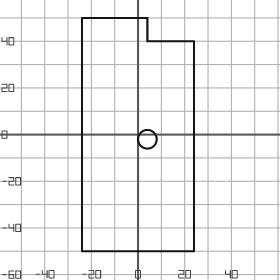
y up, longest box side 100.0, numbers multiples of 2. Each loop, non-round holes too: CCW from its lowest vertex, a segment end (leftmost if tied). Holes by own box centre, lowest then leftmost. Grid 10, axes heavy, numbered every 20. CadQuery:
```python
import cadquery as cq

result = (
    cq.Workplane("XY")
    .moveTo(-24.0, -50.0)
    .lineTo(24.0, -50.0)
    .lineTo(24.0, 40.0)
    .lineTo(4.0, 40.0)
    .lineTo(4.0, 50.0)
    .lineTo(-24.0, 50.0)
    .close()
    .moveTo(4.0, -2.0)
    .circle(4.0)
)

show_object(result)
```